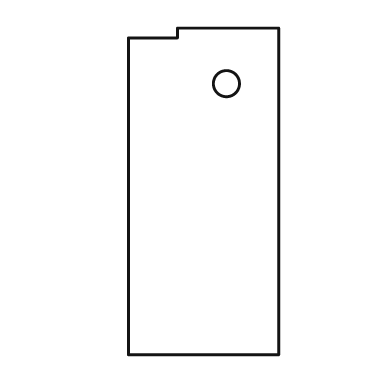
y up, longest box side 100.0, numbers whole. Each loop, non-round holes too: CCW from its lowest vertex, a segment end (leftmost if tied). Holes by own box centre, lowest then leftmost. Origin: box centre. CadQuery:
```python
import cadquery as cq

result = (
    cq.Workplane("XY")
    .moveTo(-23.0, -50.0)
    .lineTo(23.0, -50.0)
    .lineTo(23.0, 50.0)
    .lineTo(-8.0, 50.0)
    .lineTo(-8.0, 47.0)
    .lineTo(-23.0, 47.0)
    .close()
    .moveTo(7.0, 33.0)
    .circle(4.0)
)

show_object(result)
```